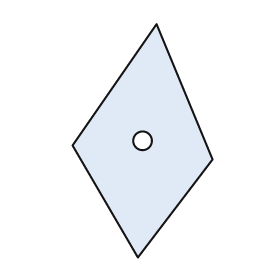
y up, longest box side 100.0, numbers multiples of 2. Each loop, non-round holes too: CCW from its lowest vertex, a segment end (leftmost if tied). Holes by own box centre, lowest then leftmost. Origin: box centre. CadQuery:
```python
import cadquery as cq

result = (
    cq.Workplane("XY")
    .moveTo(-2.0, -50.0)
    .lineTo(30.0, -8.0)
    .lineTo(6.0, 50.0)
    .lineTo(-30.0, -2.0)
    .close()
    .moveTo(0.0, 0.0)
    .circle(4.0)
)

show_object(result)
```